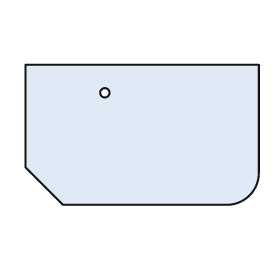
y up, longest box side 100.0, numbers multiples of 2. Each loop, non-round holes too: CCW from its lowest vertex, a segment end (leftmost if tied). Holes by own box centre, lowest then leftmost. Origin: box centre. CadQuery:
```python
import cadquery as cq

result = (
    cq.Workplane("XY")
    .moveTo(-34.0, -30.0)
    .lineTo(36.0, -30.0)
    .threePointArc((46.0, -26.0), (50.0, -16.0))
    .lineTo(50.0, 30.0)
    .lineTo(-50.0, 30.0)
    .lineTo(-50.0, -14.0)
    .close()
    .moveTo(-16.0, 18.0)
    .circle(2.0)
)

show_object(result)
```